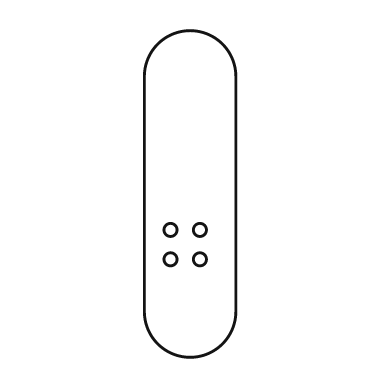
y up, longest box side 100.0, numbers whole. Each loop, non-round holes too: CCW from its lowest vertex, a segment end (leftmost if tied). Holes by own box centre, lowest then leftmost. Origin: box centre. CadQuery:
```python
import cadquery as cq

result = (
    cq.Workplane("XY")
    .moveTo(-14.0, -36.0)
    .threePointArc((0.0, -50.0), (14.0, -36.0))
    .lineTo(14.0, 36.0)
    .threePointArc((0.0, 50.0), (-14.0, 36.0))
    .close()
    .moveTo(-6.0, -20.0)
    .circle(2.0)
    .moveTo(3.0, -20.0)
    .circle(2.0)
    .moveTo(-6.0, -11.0)
    .circle(2.0)
    .moveTo(3.0, -11.0)
    .circle(2.0)
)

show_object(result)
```